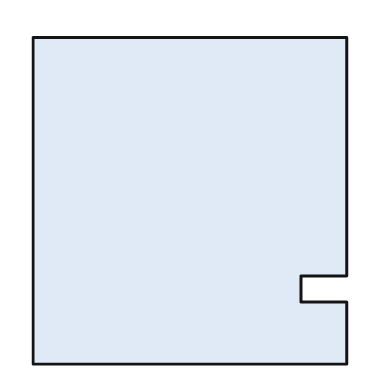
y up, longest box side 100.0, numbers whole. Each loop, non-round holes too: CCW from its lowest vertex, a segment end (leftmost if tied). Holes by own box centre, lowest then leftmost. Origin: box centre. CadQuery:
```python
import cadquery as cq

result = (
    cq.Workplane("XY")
    .moveTo(-48.0, -50.0)
    .lineTo(48.0, -50.0)
    .lineTo(48.0, -31.0)
    .lineTo(34.0, -31.0)
    .lineTo(34.0, -23.0)
    .lineTo(48.0, -23.0)
    .lineTo(48.0, 50.0)
    .lineTo(-48.0, 50.0)
    .close()
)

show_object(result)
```